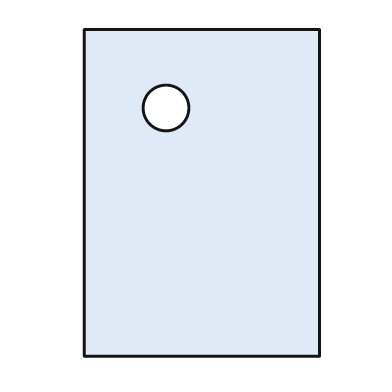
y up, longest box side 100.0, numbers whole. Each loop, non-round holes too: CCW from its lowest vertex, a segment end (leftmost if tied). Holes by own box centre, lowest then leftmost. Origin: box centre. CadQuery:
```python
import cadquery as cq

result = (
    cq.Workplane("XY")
    .moveTo(-36.0, -50.0)
    .lineTo(36.0, -50.0)
    .lineTo(36.0, 50.0)
    .lineTo(-36.0, 50.0)
    .close()
    .moveTo(-11.0, 26.0)
    .circle(7.0)
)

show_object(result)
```